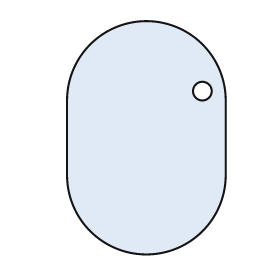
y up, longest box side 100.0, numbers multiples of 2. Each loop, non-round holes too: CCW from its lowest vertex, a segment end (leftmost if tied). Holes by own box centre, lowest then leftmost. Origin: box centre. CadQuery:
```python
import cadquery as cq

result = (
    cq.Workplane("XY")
    .moveTo(-34.0, -16.0)
    .threePointArc((0.0, -50.0), (34.0, -16.0))
    .lineTo(34.0, 16.0)
    .threePointArc((0.0, 50.0), (-34.0, 16.0))
    .close()
    .moveTo(24.0, 20.0)
    .circle(4.0)
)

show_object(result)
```